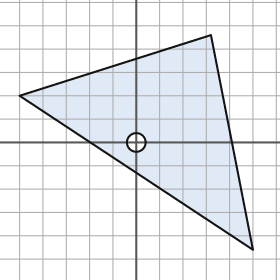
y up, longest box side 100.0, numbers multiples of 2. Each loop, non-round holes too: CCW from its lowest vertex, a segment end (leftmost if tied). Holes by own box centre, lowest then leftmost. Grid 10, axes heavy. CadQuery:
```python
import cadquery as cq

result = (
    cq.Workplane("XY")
    .moveTo(50.0, -46.0)
    .lineTo(32.0, 46.0)
    .lineTo(-50.0, 20.0)
    .close()
    .moveTo(0.0, 0.0)
    .circle(4.0)
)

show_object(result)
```